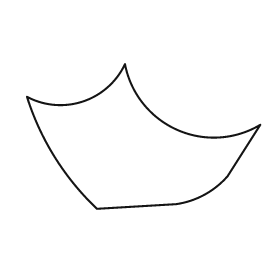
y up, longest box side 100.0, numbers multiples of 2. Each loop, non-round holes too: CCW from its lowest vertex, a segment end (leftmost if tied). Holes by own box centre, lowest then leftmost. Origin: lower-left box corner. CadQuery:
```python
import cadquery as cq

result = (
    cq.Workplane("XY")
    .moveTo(30.0, 0.0)
    .lineTo(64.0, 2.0)
    .threePointArc((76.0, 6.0), (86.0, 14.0))
    .lineTo(100.0, 36.0)
    .threePointArc((64.0, 34.0), (42.0, 62.0))
    .threePointArc((24.0, 46.0), (0.0, 48.0))
    .threePointArc((12.0, 22.0), (30.0, 0.0))
    .close()
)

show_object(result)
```